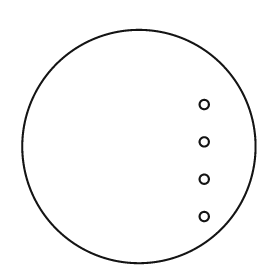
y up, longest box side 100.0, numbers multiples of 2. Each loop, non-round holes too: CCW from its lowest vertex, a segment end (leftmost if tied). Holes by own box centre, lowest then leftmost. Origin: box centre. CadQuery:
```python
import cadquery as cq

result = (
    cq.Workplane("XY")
    .moveTo(0.0, 0.0)
    .circle(50.0)
    .moveTo(28.0, -30.0)
    .circle(2.0)
    .moveTo(28.0, -14.0)
    .circle(2.0)
    .moveTo(28.0, 2.0)
    .circle(2.0)
    .moveTo(28.0, 18.0)
    .circle(2.0)
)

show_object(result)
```